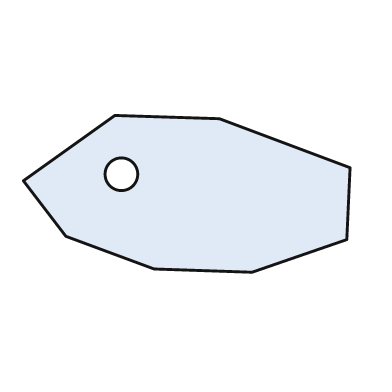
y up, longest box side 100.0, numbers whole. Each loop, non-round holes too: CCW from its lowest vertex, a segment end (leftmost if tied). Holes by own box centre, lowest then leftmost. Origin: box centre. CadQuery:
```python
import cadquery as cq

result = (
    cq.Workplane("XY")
    .moveTo(20.0, -24.0)
    .lineTo(49.0, -14.0)
    .lineTo(50.0, 8.0)
    .lineTo(10.0, 23.0)
    .lineTo(-22.0, 24.0)
    .lineTo(-50.0, 4.0)
    .lineTo(-37.0, -13.0)
    .lineTo(-10.0, -23.0)
    .close()
    .moveTo(-20.0, 6.0)
    .circle(5.0)
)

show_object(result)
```